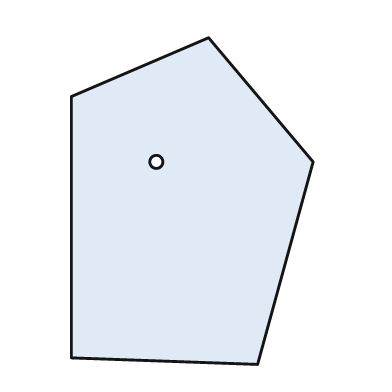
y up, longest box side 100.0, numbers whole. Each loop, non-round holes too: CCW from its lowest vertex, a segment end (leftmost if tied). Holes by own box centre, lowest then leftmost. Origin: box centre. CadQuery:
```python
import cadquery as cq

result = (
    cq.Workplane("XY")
    .moveTo(20.0, -50.0)
    .lineTo(37.0, 12.0)
    .lineTo(5.0, 50.0)
    .lineTo(-37.0, 32.0)
    .lineTo(-37.0, -48.0)
    .close()
    .moveTo(-11.0, 12.0)
    .circle(2.0)
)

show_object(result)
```